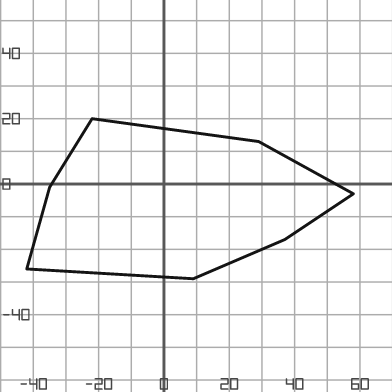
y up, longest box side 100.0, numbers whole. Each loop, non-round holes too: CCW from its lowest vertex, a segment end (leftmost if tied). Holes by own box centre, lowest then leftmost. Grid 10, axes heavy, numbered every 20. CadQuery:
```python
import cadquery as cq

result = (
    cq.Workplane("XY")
    .moveTo(9.0, -29.0)
    .lineTo(37.0, -17.0)
    .lineTo(58.0, -3.0)
    .lineTo(29.0, 13.0)
    .lineTo(-22.0, 20.0)
    .lineTo(-35.0, -1.0)
    .lineTo(-42.0, -26.0)
    .close()
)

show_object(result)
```